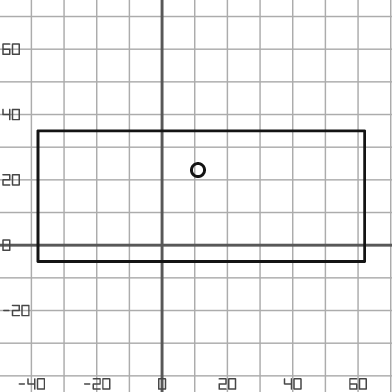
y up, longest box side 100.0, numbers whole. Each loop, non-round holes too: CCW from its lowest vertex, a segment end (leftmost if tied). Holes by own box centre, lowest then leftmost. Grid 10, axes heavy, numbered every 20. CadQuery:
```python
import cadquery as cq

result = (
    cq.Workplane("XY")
    .moveTo(-38.0, -5.0)
    .lineTo(62.0, -5.0)
    .lineTo(62.0, 35.0)
    .lineTo(-38.0, 35.0)
    .close()
    .moveTo(11.0, 23.0)
    .circle(2.0)
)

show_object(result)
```